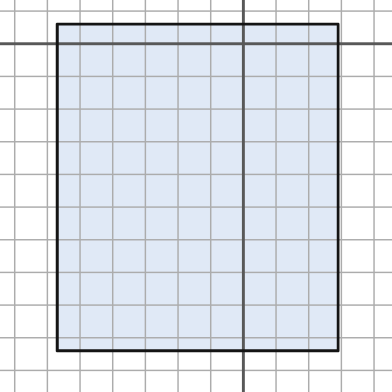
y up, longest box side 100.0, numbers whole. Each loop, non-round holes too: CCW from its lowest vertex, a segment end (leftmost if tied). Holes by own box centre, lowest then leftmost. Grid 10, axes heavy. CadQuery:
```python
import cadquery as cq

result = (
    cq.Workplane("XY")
    .moveTo(-57.0, -94.0)
    .lineTo(29.0, -94.0)
    .lineTo(29.0, 6.0)
    .lineTo(-57.0, 6.0)
    .close()
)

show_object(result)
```